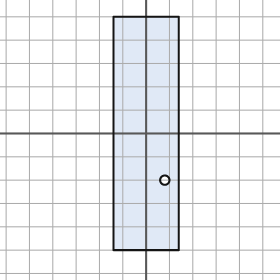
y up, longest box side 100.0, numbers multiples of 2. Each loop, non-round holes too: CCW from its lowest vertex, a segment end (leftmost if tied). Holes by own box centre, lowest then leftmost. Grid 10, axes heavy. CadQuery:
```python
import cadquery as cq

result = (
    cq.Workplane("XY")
    .moveTo(-14.0, -50.0)
    .lineTo(14.0, -50.0)
    .lineTo(14.0, 50.0)
    .lineTo(-14.0, 50.0)
    .close()
    .moveTo(8.0, -20.0)
    .circle(2.0)
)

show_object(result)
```